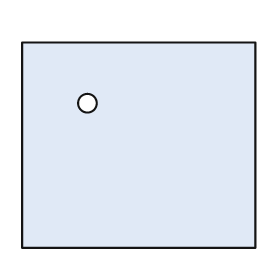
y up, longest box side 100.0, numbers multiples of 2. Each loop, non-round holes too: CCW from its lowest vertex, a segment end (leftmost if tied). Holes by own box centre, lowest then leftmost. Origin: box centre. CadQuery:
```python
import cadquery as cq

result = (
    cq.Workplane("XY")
    .moveTo(-50.0, -44.0)
    .lineTo(50.0, -44.0)
    .lineTo(50.0, 44.0)
    .lineTo(-50.0, 44.0)
    .close()
    .moveTo(-22.0, 18.0)
    .circle(4.0)
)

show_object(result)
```